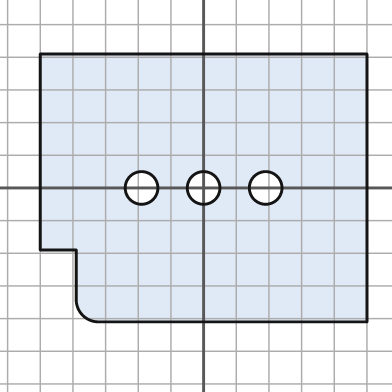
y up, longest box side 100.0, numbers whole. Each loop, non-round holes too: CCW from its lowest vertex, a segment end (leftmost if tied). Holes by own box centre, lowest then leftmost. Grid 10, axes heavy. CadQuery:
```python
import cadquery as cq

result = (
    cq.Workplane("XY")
    .moveTo(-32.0, -41.0)
    .lineTo(50.0, -41.0)
    .lineTo(50.0, 41.0)
    .lineTo(-50.0, 41.0)
    .lineTo(-50.0, -19.0)
    .lineTo(-39.0, -19.0)
    .lineTo(-39.0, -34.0)
    .threePointArc((-37.0, -39.0), (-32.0, -41.0))
    .close()
    .moveTo(-19.0, 0.0)
    .circle(5.0)
    .moveTo(0.0, 0.0)
    .circle(5.0)
    .moveTo(19.0, 0.0)
    .circle(5.0)
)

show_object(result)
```